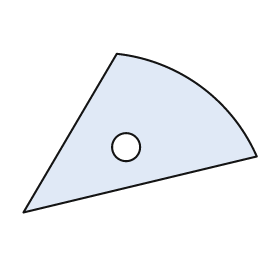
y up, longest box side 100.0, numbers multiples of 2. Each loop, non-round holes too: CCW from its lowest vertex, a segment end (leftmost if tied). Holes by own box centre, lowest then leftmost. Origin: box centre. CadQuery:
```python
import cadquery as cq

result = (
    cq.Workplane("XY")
    .moveTo(-50.0, -34.0)
    .lineTo(50.0, -10.0)
    .threePointArc((26.0, 20.0), (-10.0, 34.0))
    .close()
    .moveTo(-6.0, -6.0)
    .circle(6.0)
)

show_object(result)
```